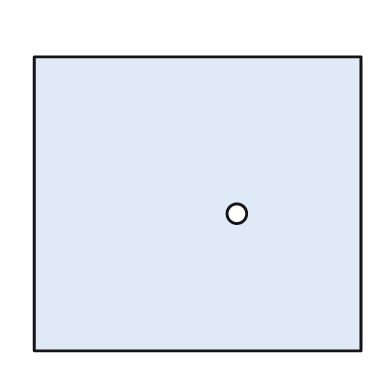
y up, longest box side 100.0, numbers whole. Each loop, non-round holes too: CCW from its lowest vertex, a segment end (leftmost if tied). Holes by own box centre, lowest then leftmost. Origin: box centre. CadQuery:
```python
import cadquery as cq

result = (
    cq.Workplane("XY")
    .moveTo(-50.0, -45.0)
    .lineTo(50.0, -45.0)
    .lineTo(50.0, 45.0)
    .lineTo(-50.0, 45.0)
    .close()
    .moveTo(12.0, -3.0)
    .circle(3.0)
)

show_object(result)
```